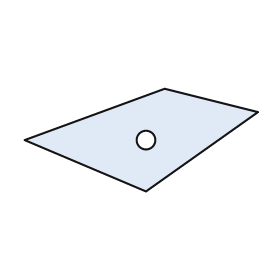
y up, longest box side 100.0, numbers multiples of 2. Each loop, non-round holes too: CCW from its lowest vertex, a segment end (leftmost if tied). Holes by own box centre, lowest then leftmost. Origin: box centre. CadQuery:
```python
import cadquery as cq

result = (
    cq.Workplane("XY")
    .moveTo(2.0, -22.0)
    .lineTo(50.0, 12.0)
    .lineTo(10.0, 22.0)
    .lineTo(-50.0, 0.0)
    .close()
    .moveTo(2.0, 0.0)
    .circle(4.0)
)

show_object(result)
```